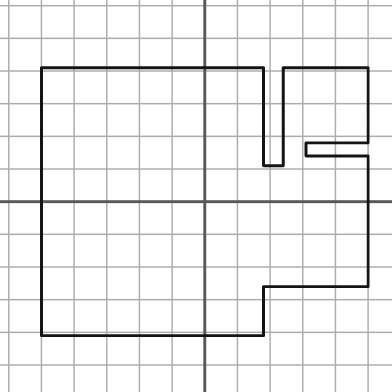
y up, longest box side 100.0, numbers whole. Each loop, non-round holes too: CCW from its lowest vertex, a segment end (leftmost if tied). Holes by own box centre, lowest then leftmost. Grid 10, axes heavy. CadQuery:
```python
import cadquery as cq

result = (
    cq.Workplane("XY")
    .moveTo(-50.0, -41.0)
    .lineTo(18.0, -41.0)
    .lineTo(18.0, -26.0)
    .lineTo(50.0, -26.0)
    .lineTo(50.0, 14.0)
    .lineTo(31.0, 14.0)
    .lineTo(31.0, 18.0)
    .lineTo(50.0, 18.0)
    .lineTo(50.0, 41.0)
    .lineTo(24.0, 41.0)
    .lineTo(24.0, 11.0)
    .lineTo(18.0, 11.0)
    .lineTo(18.0, 41.0)
    .lineTo(-50.0, 41.0)
    .close()
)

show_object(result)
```